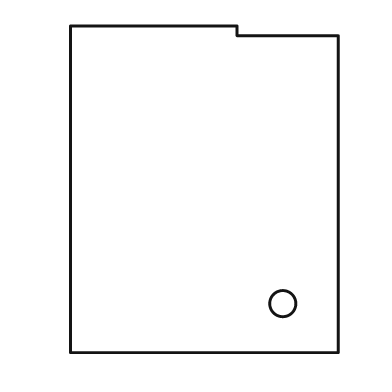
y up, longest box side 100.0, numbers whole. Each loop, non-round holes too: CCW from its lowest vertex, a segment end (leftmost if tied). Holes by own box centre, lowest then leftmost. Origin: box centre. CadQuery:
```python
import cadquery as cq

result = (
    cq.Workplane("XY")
    .moveTo(-41.0, -50.0)
    .lineTo(41.0, -50.0)
    .lineTo(41.0, 47.0)
    .lineTo(10.0, 47.0)
    .lineTo(10.0, 50.0)
    .lineTo(-41.0, 50.0)
    .close()
    .moveTo(24.0, -35.0)
    .circle(4.0)
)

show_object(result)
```